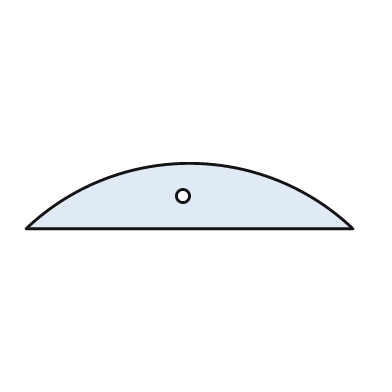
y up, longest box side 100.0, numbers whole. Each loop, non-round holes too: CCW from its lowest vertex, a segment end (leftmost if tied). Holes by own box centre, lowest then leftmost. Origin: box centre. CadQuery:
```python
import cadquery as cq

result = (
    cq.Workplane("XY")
    .moveTo(-50.0, -10.0)
    .lineTo(50.0, -10.0)
    .threePointArc((0.0, 10.0), (-50.0, -10.0))
    .close()
    .moveTo(-2.0, 0.0)
    .circle(2.0)
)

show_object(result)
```